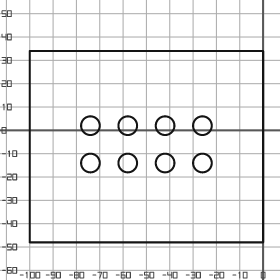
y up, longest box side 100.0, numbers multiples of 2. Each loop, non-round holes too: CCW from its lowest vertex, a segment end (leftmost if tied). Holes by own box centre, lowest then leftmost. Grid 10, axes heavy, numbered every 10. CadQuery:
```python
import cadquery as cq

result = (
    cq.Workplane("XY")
    .moveTo(-100.0, -48.0)
    .lineTo(0.0, -48.0)
    .lineTo(0.0, 34.0)
    .lineTo(-100.0, 34.0)
    .close()
    .moveTo(-74.0, -14.0)
    .circle(4.0)
    .moveTo(-58.0, -14.0)
    .circle(4.0)
    .moveTo(-42.0, -14.0)
    .circle(4.0)
    .moveTo(-26.0, -14.0)
    .circle(4.0)
    .moveTo(-74.0, 2.0)
    .circle(4.0)
    .moveTo(-58.0, 2.0)
    .circle(4.0)
    .moveTo(-42.0, 2.0)
    .circle(4.0)
    .moveTo(-26.0, 2.0)
    .circle(4.0)
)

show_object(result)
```